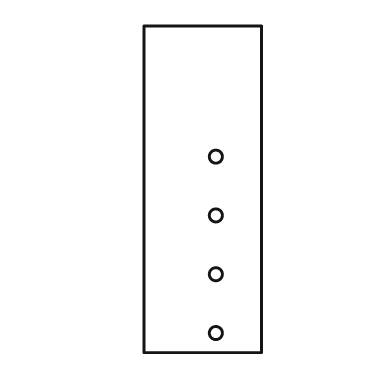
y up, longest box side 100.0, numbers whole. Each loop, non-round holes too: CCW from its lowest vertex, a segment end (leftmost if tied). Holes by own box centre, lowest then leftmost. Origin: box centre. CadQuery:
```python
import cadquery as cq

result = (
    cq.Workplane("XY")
    .moveTo(-18.0, -50.0)
    .lineTo(18.0, -50.0)
    .lineTo(18.0, 50.0)
    .lineTo(-18.0, 50.0)
    .close()
    .moveTo(4.0, -44.0)
    .circle(2.0)
    .moveTo(4.0, -26.0)
    .circle(2.0)
    .moveTo(4.0, -8.0)
    .circle(2.0)
    .moveTo(4.0, 10.0)
    .circle(2.0)
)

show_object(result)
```